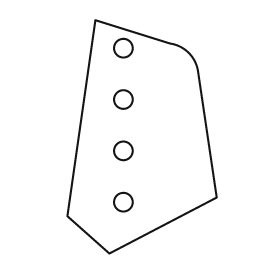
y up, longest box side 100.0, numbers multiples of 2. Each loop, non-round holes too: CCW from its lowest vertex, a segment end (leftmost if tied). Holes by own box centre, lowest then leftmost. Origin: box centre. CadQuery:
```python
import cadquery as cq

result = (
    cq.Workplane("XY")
    .moveTo(-14.0, -50.0)
    .lineTo(32.0, -26.0)
    .lineTo(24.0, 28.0)
    .threePointArc((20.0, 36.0), (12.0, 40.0))
    .lineTo(-20.0, 50.0)
    .lineTo(-32.0, -34.0)
    .close()
    .moveTo(-8.0, -28.0)
    .circle(4.0)
    .moveTo(-8.0, -6.0)
    .circle(4.0)
    .moveTo(-8.0, 16.0)
    .circle(4.0)
    .moveTo(-8.0, 38.0)
    .circle(4.0)
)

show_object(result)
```